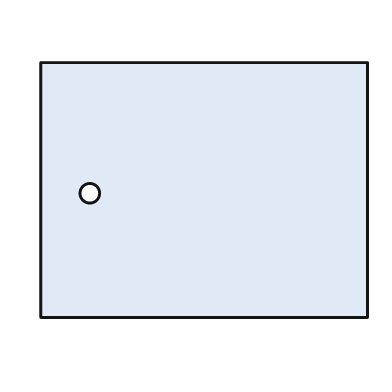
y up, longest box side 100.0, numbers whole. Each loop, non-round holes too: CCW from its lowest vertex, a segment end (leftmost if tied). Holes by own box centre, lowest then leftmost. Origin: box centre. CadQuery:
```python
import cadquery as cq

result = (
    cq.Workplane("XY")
    .moveTo(-50.0, -39.0)
    .lineTo(50.0, -39.0)
    .lineTo(50.0, 39.0)
    .lineTo(-50.0, 39.0)
    .close()
    .moveTo(-35.0, -1.0)
    .circle(3.0)
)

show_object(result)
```